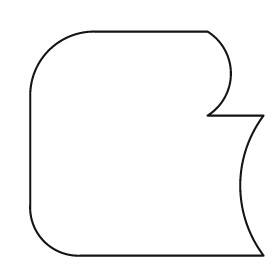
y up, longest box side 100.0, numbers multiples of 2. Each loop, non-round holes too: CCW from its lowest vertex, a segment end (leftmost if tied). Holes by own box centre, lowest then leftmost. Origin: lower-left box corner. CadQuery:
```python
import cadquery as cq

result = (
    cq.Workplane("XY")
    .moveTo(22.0, 0.0)
    .lineTo(100.0, 0.0)
    .threePointArc((90.0, 30.0), (100.0, 60.0))
    .lineTo(76.0, 60.0)
    .threePointArc((86.0, 78.0), (76.0, 96.0))
    .lineTo(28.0, 96.0)
    .threePointArc((8.0, 88.0), (0.0, 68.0))
    .lineTo(0.0, 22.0)
    .threePointArc((6.0, 6.0), (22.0, 0.0))
    .close()
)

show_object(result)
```